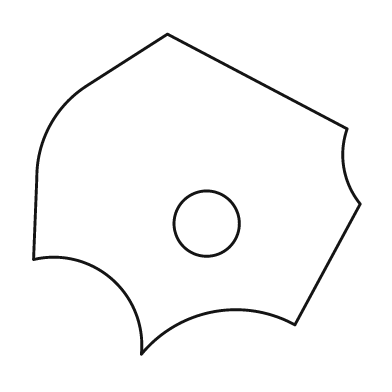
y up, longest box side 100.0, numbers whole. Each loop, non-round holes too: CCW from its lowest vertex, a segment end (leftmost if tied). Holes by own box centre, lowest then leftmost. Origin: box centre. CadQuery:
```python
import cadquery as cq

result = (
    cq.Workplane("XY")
    .moveTo(-17.0, -49.0)
    .threePointArc((5.0, -36.0), (30.0, -40.0))
    .lineTo(50.0, -3.0)
    .threePointArc((45.0, 8.0), (46.0, 20.0))
    .lineTo(-9.0, 49.0)
    .lineTo(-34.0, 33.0)
    .threePointArc((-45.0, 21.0), (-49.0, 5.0))
    .lineTo(-50.0, -20.0)
    .threePointArc((-26.0, -26.0), (-17.0, -49.0))
    .close()
    .moveTo(3.0, -9.0)
    .circle(10.0)
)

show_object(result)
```